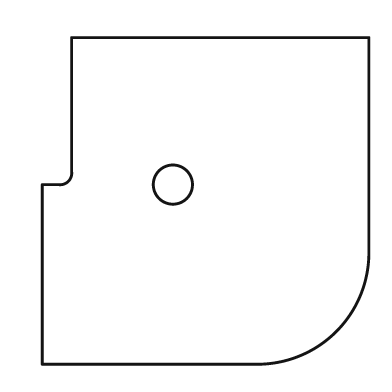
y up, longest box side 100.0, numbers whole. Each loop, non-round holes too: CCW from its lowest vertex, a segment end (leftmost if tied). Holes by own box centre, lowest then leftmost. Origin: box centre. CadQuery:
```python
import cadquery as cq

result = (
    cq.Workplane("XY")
    .moveTo(-50.0, -50.0)
    .lineTo(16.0, -50.0)
    .threePointArc((40.0, -40.0), (50.0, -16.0))
    .lineTo(50.0, 50.0)
    .lineTo(-41.0, 50.0)
    .lineTo(-41.0, 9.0)
    .threePointArc((-42.0, 6.0), (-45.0, 5.0))
    .lineTo(-50.0, 5.0)
    .close()
    .moveTo(-10.0, 5.0)
    .circle(6.0)
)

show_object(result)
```